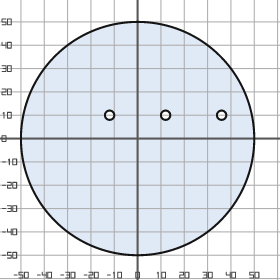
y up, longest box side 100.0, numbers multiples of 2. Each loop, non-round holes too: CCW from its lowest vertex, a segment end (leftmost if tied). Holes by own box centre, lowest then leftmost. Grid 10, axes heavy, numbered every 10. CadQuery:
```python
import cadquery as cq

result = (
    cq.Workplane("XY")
    .moveTo(0.0, 0.0)
    .circle(50.0)
    .moveTo(-12.0, 10.0)
    .circle(2.0)
    .moveTo(12.0, 10.0)
    .circle(2.0)
    .moveTo(36.0, 10.0)
    .circle(2.0)
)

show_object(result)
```